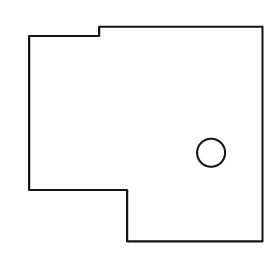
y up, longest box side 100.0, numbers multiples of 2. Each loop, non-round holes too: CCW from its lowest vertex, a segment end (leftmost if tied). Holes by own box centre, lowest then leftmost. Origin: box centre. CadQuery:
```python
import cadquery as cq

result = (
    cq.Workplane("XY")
    .moveTo(-8.0, -46.0)
    .lineTo(50.0, -46.0)
    .lineTo(50.0, 46.0)
    .lineTo(-20.0, 46.0)
    .lineTo(-20.0, 42.0)
    .lineTo(-50.0, 42.0)
    .lineTo(-50.0, -24.0)
    .lineTo(-8.0, -24.0)
    .close()
    .moveTo(28.0, -8.0)
    .circle(6.0)
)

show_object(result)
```